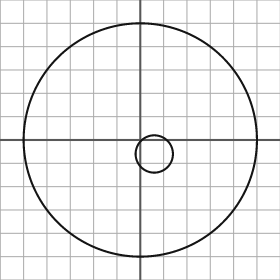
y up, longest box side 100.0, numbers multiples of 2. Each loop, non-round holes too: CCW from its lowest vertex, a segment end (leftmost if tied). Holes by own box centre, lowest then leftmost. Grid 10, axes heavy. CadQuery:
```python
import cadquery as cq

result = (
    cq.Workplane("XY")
    .moveTo(0.0, 0.0)
    .circle(50.0)
    .moveTo(6.0, -6.0)
    .circle(8.0)
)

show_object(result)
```